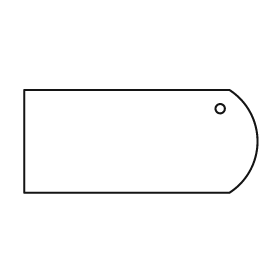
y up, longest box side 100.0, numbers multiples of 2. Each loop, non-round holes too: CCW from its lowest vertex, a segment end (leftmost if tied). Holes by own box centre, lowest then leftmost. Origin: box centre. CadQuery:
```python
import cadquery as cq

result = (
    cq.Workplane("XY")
    .moveTo(-50.0, -22.0)
    .lineTo(38.0, -22.0)
    .threePointArc((50.0, 0.0), (38.0, 22.0))
    .lineTo(-50.0, 22.0)
    .close()
    .moveTo(34.0, 14.0)
    .circle(2.0)
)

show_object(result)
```